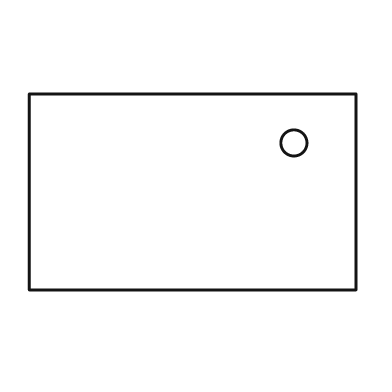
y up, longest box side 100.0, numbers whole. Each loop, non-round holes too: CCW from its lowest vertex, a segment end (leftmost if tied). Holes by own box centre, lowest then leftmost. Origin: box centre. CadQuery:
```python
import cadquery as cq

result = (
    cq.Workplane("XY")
    .moveTo(-50.0, -30.0)
    .lineTo(50.0, -30.0)
    .lineTo(50.0, 30.0)
    .lineTo(-50.0, 30.0)
    .close()
    .moveTo(31.0, 15.0)
    .circle(4.0)
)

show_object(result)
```